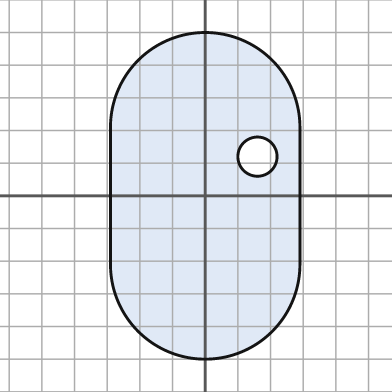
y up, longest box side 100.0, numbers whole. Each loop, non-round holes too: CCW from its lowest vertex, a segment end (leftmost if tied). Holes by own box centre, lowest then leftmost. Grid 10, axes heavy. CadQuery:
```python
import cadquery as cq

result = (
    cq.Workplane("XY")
    .moveTo(-29.0, -21.0)
    .threePointArc((0.0, -50.0), (29.0, -21.0))
    .lineTo(29.0, 21.0)
    .threePointArc((0.0, 50.0), (-29.0, 21.0))
    .close()
    .moveTo(16.0, 12.0)
    .circle(6.0)
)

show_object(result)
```